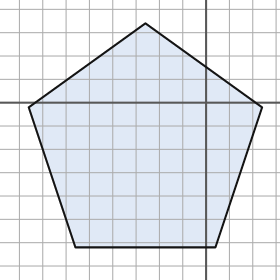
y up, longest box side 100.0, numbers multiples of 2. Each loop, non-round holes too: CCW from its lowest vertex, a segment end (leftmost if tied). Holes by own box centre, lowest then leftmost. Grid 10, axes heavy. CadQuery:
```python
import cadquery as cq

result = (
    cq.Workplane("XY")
    .moveTo(-56.0, -62.0)
    .lineTo(4.0, -62.0)
    .lineTo(24.0, -2.0)
    .lineTo(-26.0, 34.0)
    .lineTo(-76.0, -2.0)
    .close()
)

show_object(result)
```